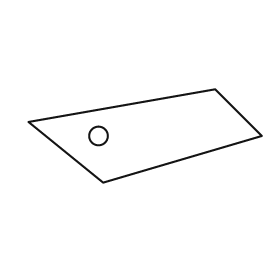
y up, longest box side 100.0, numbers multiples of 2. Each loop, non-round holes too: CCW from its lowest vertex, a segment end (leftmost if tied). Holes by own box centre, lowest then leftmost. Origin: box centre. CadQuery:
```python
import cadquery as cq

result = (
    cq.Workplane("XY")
    .moveTo(-18.0, -20.0)
    .lineTo(50.0, 0.0)
    .lineTo(30.0, 20.0)
    .lineTo(-50.0, 6.0)
    .close()
    .moveTo(-20.0, 0.0)
    .circle(4.0)
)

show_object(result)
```